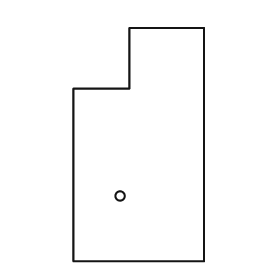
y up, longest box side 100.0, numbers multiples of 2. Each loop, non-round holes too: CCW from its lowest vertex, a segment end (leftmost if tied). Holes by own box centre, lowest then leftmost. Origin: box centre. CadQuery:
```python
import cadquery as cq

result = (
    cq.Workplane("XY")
    .moveTo(-28.0, -50.0)
    .lineTo(28.0, -50.0)
    .lineTo(28.0, 50.0)
    .lineTo(-4.0, 50.0)
    .lineTo(-4.0, 24.0)
    .lineTo(-28.0, 24.0)
    .close()
    .moveTo(-8.0, -22.0)
    .circle(2.0)
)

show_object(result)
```